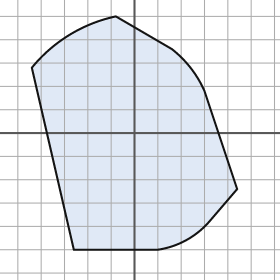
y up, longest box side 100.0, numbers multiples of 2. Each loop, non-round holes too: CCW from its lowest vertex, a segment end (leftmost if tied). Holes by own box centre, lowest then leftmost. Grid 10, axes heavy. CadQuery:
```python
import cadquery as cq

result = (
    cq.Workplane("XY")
    .moveTo(-26.0, -50.0)
    .lineTo(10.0, -50.0)
    .threePointArc((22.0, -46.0), (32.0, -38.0))
    .lineTo(44.0, -24.0)
    .lineTo(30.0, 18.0)
    .threePointArc((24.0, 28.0), (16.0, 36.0))
    .lineTo(-8.0, 50.0)
    .threePointArc((-28.0, 42.0), (-44.0, 28.0))
    .close()
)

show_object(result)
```